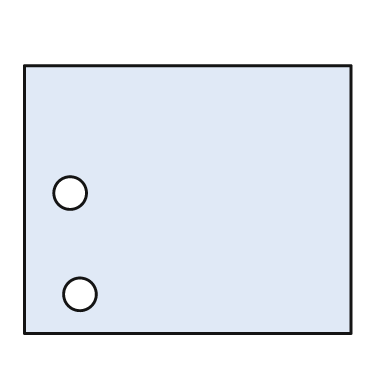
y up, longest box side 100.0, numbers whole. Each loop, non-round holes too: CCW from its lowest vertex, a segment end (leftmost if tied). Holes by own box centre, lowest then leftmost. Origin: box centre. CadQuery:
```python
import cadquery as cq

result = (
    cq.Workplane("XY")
    .moveTo(-50.0, -41.0)
    .lineTo(50.0, -41.0)
    .lineTo(50.0, 41.0)
    .lineTo(-50.0, 41.0)
    .close()
    .moveTo(-33.0, -29.0)
    .circle(5.0)
    .moveTo(-36.0, 2.0)
    .circle(5.0)
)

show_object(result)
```